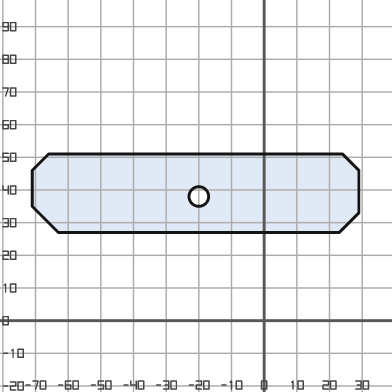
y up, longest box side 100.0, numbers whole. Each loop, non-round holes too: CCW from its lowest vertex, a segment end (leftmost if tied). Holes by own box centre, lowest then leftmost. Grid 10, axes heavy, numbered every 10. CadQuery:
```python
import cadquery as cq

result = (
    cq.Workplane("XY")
    .moveTo(-63.0, 27.0)
    .lineTo(23.0, 27.0)
    .lineTo(29.0, 33.0)
    .lineTo(29.0, 46.0)
    .lineTo(24.0, 51.0)
    .lineTo(-66.0, 51.0)
    .lineTo(-71.0, 46.0)
    .lineTo(-71.0, 35.0)
    .close()
    .moveTo(-20.0, 38.0)
    .circle(3.0)
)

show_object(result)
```